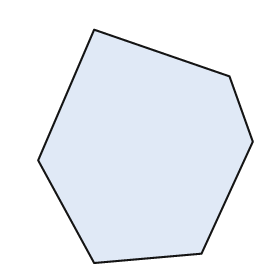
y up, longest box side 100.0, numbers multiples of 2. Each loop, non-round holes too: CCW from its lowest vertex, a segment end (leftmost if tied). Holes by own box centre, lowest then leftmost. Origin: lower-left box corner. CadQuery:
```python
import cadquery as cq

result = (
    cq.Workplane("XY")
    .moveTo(24.0, 0.0)
    .lineTo(70.0, 4.0)
    .lineTo(92.0, 52.0)
    .lineTo(82.0, 80.0)
    .lineTo(24.0, 100.0)
    .lineTo(0.0, 44.0)
    .close()
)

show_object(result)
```